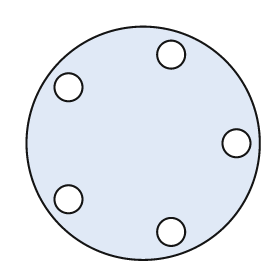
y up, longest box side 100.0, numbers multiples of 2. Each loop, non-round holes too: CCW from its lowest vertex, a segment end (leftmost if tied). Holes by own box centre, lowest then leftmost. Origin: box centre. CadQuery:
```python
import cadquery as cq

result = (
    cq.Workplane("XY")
    .moveTo(0.0, 0.0)
    .circle(50.0)
    .moveTo(12.0, -38.0)
    .circle(6.0)
    .moveTo(-32.0, -24.0)
    .circle(6.0)
    .moveTo(40.0, 0.0)
    .circle(6.0)
    .moveTo(-32.0, 24.0)
    .circle(6.0)
    .moveTo(12.0, 38.0)
    .circle(6.0)
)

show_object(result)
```